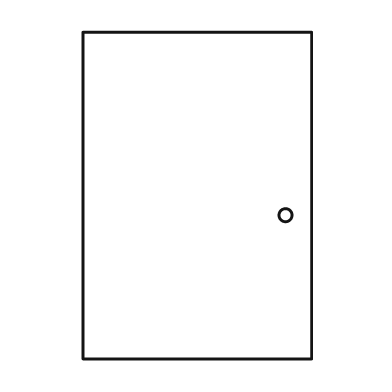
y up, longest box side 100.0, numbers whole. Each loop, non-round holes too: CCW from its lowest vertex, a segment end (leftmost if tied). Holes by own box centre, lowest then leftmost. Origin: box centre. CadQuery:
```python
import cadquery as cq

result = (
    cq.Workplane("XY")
    .moveTo(-35.0, -50.0)
    .lineTo(35.0, -50.0)
    .lineTo(35.0, 50.0)
    .lineTo(-35.0, 50.0)
    .close()
    .moveTo(27.0, -6.0)
    .circle(2.0)
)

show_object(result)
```